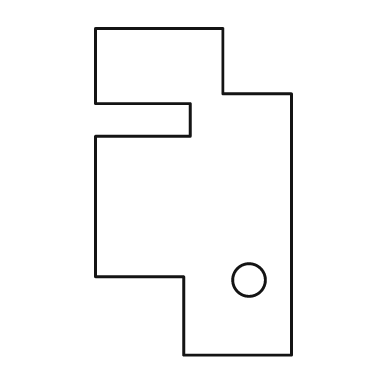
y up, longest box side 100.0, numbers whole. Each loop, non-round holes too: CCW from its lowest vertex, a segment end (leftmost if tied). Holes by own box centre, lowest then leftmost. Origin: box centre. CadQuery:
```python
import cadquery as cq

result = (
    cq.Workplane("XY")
    .moveTo(-3.0, -50.0)
    .lineTo(30.0, -50.0)
    .lineTo(30.0, 30.0)
    .lineTo(9.0, 30.0)
    .lineTo(9.0, 50.0)
    .lineTo(-30.0, 50.0)
    .lineTo(-30.0, 27.0)
    .lineTo(-1.0, 27.0)
    .lineTo(-1.0, 17.0)
    .lineTo(-30.0, 17.0)
    .lineTo(-30.0, -26.0)
    .lineTo(-3.0, -26.0)
    .close()
    .moveTo(17.0, -27.0)
    .circle(5.0)
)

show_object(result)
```